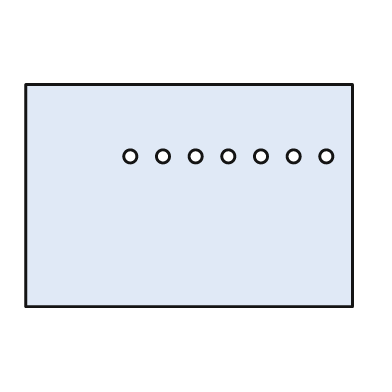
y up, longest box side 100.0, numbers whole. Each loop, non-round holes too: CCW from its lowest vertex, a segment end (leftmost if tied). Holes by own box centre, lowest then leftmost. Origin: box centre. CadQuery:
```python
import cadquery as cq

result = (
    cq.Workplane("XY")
    .moveTo(-50.0, -34.0)
    .lineTo(50.0, -34.0)
    .lineTo(50.0, 34.0)
    .lineTo(-50.0, 34.0)
    .close()
    .moveTo(-18.0, 12.0)
    .circle(2.0)
    .moveTo(-8.0, 12.0)
    .circle(2.0)
    .moveTo(2.0, 12.0)
    .circle(2.0)
    .moveTo(12.0, 12.0)
    .circle(2.0)
    .moveTo(22.0, 12.0)
    .circle(2.0)
    .moveTo(32.0, 12.0)
    .circle(2.0)
    .moveTo(42.0, 12.0)
    .circle(2.0)
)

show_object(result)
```